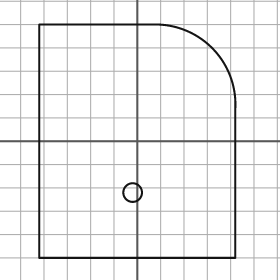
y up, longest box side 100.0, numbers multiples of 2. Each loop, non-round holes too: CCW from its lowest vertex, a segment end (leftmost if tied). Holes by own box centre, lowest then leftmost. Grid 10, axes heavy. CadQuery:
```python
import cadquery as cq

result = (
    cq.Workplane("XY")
    .moveTo(-42.0, -50.0)
    .lineTo(42.0, -50.0)
    .lineTo(42.0, 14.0)
    .threePointArc((32.0, 40.0), (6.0, 50.0))
    .lineTo(-42.0, 50.0)
    .close()
    .moveTo(-2.0, -22.0)
    .circle(4.0)
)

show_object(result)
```